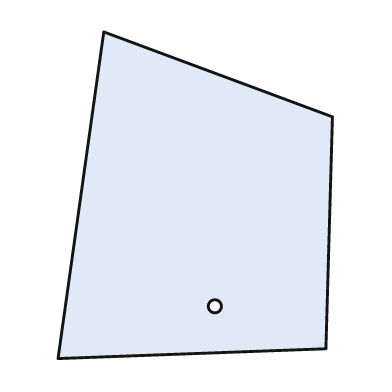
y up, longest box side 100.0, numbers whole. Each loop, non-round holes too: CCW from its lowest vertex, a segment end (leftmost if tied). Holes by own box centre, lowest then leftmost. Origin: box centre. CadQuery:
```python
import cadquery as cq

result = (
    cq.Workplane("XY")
    .moveTo(-42.0, -50.0)
    .lineTo(40.0, -47.0)
    .lineTo(42.0, 24.0)
    .lineTo(-28.0, 50.0)
    .close()
    .moveTo(6.0, -34.0)
    .circle(2.0)
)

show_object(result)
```